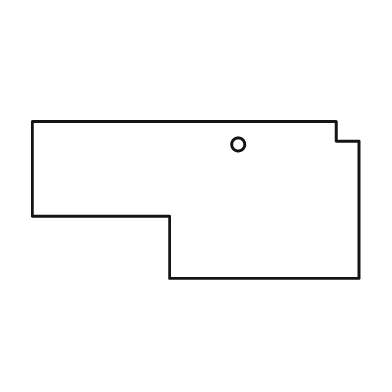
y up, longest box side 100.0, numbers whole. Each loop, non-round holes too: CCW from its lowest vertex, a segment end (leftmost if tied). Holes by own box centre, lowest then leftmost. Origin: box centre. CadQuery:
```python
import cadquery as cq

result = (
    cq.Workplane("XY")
    .moveTo(-8.0, -24.0)
    .lineTo(50.0, -24.0)
    .lineTo(50.0, 18.0)
    .lineTo(43.0, 18.0)
    .lineTo(43.0, 24.0)
    .lineTo(-50.0, 24.0)
    .lineTo(-50.0, -5.0)
    .lineTo(-8.0, -5.0)
    .close()
    .moveTo(13.0, 17.0)
    .circle(2.0)
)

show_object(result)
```